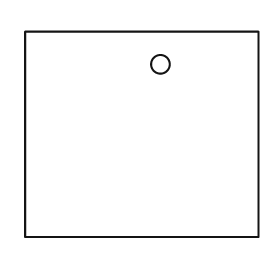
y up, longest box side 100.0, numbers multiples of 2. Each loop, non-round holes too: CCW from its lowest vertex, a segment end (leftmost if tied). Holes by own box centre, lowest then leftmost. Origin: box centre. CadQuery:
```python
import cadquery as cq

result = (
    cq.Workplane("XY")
    .moveTo(-50.0, -44.0)
    .lineTo(50.0, -44.0)
    .lineTo(50.0, 44.0)
    .lineTo(-50.0, 44.0)
    .close()
    .moveTo(8.0, 30.0)
    .circle(4.0)
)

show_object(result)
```